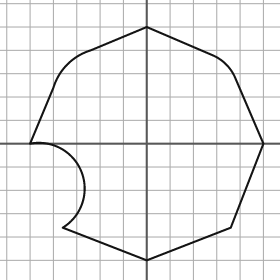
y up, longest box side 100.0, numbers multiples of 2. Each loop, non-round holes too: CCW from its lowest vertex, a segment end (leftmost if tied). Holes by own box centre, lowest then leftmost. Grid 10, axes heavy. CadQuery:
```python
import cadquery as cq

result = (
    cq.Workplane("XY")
    .moveTo(0.0, -50.0)
    .lineTo(36.0, -36.0)
    .lineTo(50.0, 0.0)
    .lineTo(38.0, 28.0)
    .threePointArc((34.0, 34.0), (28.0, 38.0))
    .lineTo(0.0, 50.0)
    .lineTo(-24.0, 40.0)
    .threePointArc((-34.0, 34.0), (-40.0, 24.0))
    .lineTo(-50.0, 0.0)
    .threePointArc((-28.0, -12.0), (-36.0, -36.0))
    .close()
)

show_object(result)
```